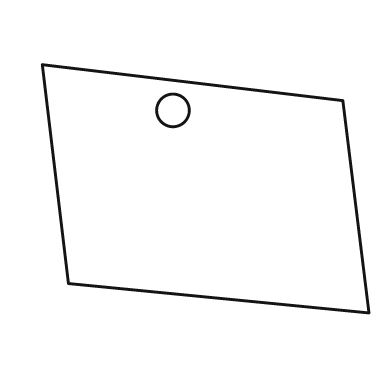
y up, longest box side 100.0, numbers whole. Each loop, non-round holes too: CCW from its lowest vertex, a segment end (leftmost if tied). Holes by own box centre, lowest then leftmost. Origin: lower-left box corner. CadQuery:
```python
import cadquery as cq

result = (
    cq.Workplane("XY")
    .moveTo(100.0, 0.0)
    .lineTo(92.0, 65.0)
    .lineTo(0.0, 76.0)
    .lineTo(8.0, 9.0)
    .close()
    .moveTo(40.0, 62.0)
    .circle(5.0)
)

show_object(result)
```